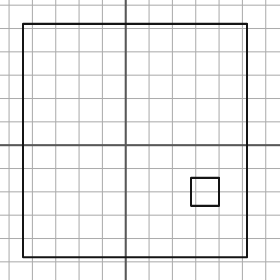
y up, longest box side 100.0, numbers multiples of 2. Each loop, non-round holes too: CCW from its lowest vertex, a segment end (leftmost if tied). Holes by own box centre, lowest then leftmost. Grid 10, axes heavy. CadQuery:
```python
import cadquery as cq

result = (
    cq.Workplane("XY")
    .moveTo(-44.0, -48.0)
    .lineTo(52.0, -48.0)
    .lineTo(52.0, 52.0)
    .lineTo(-44.0, 52.0)
    .close()
    .moveTo(28.0, -26.0)
    .lineTo(40.0, -26.0)
    .lineTo(40.0, -14.0)
    .lineTo(28.0, -14.0)
    .close()
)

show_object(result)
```